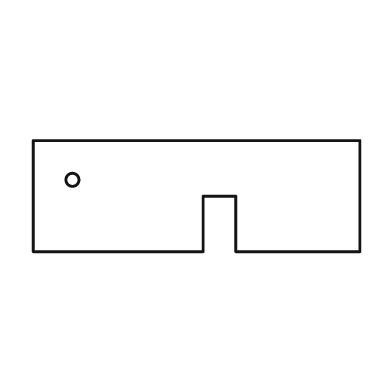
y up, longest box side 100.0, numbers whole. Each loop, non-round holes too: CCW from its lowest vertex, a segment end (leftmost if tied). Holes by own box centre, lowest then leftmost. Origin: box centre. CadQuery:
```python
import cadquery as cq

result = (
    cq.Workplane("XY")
    .moveTo(-50.0, -17.0)
    .lineTo(2.0, -17.0)
    .lineTo(2.0, 0.0)
    .lineTo(12.0, 0.0)
    .lineTo(12.0, -17.0)
    .lineTo(50.0, -17.0)
    .lineTo(50.0, 17.0)
    .lineTo(-50.0, 17.0)
    .close()
    .moveTo(-38.0, 5.0)
    .circle(2.0)
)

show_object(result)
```